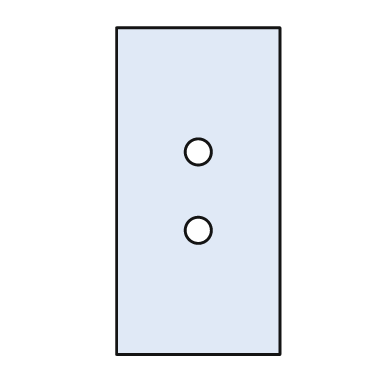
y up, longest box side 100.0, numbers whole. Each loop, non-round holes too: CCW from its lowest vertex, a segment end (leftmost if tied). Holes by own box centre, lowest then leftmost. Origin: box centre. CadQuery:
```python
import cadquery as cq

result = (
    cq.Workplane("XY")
    .moveTo(-25.0, -50.0)
    .lineTo(25.0, -50.0)
    .lineTo(25.0, 50.0)
    .lineTo(-25.0, 50.0)
    .close()
    .moveTo(0.0, -12.0)
    .circle(4.0)
    .moveTo(0.0, 12.0)
    .circle(4.0)
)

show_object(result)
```